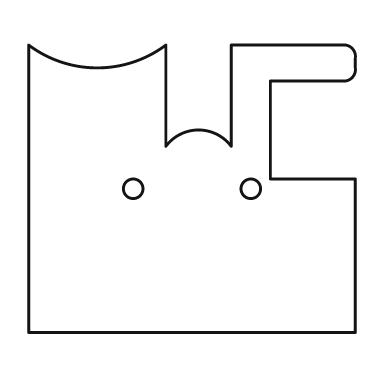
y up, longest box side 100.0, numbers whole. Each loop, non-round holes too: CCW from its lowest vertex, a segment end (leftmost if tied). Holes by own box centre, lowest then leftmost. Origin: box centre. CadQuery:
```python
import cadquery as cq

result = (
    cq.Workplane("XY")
    .moveTo(-50.0, -44.0)
    .lineTo(50.0, -44.0)
    .lineTo(50.0, 3.0)
    .lineTo(24.0, 3.0)
    .lineTo(24.0, 33.0)
    .lineTo(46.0, 33.0)
    .threePointArc((49.0, 34.0), (50.0, 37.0))
    .lineTo(50.0, 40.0)
    .threePointArc((49.0, 43.0), (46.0, 44.0))
    .lineTo(12.0, 44.0)
    .lineTo(12.0, 13.0)
    .threePointArc((2.0, 18.0), (-8.0, 13.0))
    .lineTo(-8.0, 44.0)
    .threePointArc((-29.0, 37.0), (-50.0, 44.0))
    .close()
    .moveTo(-18.0, 0.0)
    .circle(3.0)
    .moveTo(18.0, 0.0)
    .circle(3.0)
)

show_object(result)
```